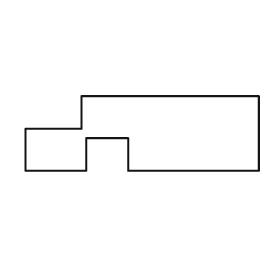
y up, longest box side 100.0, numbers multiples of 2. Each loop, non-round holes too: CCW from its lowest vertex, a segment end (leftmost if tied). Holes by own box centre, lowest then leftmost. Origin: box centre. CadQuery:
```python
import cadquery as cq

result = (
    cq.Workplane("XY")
    .moveTo(-50.0, -16.0)
    .lineTo(-24.0, -16.0)
    .lineTo(-24.0, -2.0)
    .lineTo(-6.0, -2.0)
    .lineTo(-6.0, -16.0)
    .lineTo(50.0, -16.0)
    .lineTo(50.0, 16.0)
    .lineTo(-26.0, 16.0)
    .lineTo(-26.0, 2.0)
    .lineTo(-50.0, 2.0)
    .close()
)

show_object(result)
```